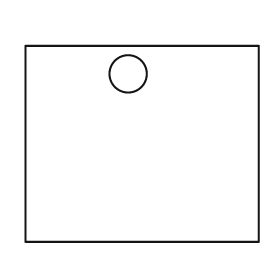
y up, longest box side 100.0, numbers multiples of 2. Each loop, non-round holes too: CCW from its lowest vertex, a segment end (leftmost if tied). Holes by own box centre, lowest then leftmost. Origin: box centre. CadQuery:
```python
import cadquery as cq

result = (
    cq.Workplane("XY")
    .moveTo(-50.0, -42.0)
    .lineTo(50.0, -42.0)
    .lineTo(50.0, 42.0)
    .lineTo(-50.0, 42.0)
    .close()
    .moveTo(-6.0, 30.0)
    .circle(8.0)
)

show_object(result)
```